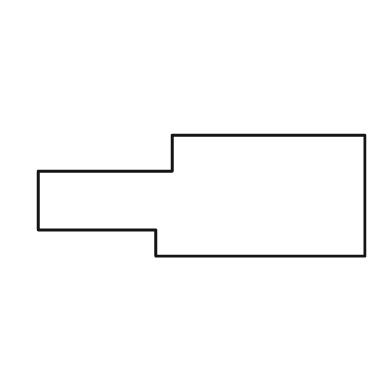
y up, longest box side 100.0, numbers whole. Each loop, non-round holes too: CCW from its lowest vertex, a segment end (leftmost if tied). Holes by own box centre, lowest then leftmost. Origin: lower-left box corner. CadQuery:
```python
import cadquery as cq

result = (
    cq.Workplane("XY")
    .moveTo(36.0, 0.0)
    .lineTo(100.0, 0.0)
    .lineTo(100.0, 37.0)
    .lineTo(41.0, 37.0)
    .lineTo(41.0, 26.0)
    .lineTo(0.0, 26.0)
    .lineTo(0.0, 8.0)
    .lineTo(36.0, 8.0)
    .close()
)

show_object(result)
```